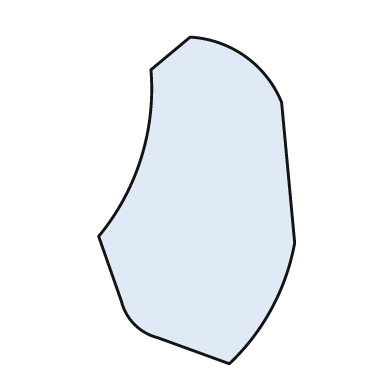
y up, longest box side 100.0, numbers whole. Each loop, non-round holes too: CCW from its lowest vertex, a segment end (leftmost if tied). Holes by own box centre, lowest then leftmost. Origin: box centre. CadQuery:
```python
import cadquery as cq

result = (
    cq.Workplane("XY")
    .moveTo(10.0, -50.0)
    .threePointArc((23.0, -33.0), (30.0, -13.0))
    .lineTo(26.0, 30.0)
    .threePointArc((15.0, 44.0), (-2.0, 50.0))
    .lineTo(-14.0, 40.0)
    .threePointArc((-17.0, 13.0), (-30.0, -11.0))
    .lineTo(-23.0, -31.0)
    .threePointArc((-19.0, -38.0), (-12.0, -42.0))
    .close()
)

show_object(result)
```